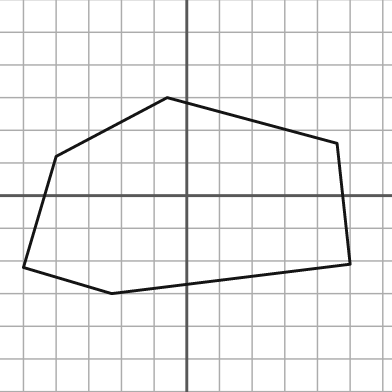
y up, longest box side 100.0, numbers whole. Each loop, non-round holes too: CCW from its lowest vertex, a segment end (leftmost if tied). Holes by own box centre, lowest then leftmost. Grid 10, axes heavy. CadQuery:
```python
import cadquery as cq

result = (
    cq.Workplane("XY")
    .moveTo(-23.0, -30.0)
    .lineTo(50.0, -21.0)
    .lineTo(46.0, 16.0)
    .lineTo(-6.0, 30.0)
    .lineTo(-40.0, 12.0)
    .lineTo(-50.0, -22.0)
    .close()
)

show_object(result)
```